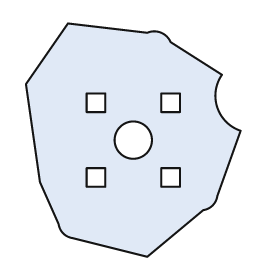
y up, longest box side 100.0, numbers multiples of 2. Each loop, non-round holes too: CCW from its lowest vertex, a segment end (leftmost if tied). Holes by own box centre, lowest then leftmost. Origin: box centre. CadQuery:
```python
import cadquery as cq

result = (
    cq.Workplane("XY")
    .moveTo(6.0, -50.0)
    .lineTo(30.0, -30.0)
    .threePointArc((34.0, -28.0), (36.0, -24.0))
    .lineTo(46.0, 4.0)
    .threePointArc((36.0, 14.0), (38.0, 28.0))
    .lineTo(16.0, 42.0)
    .threePointArc((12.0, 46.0), (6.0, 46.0))
    .lineTo(-28.0, 50.0)
    .lineTo(-46.0, 24.0)
    .lineTo(-40.0, -18.0)
    .lineTo(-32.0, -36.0)
    .threePointArc((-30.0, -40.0), (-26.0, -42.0))
    .close()
    .moveTo(-20.0, -20.0)
    .lineTo(-12.0, -20.0)
    .lineTo(-12.0, -12.0)
    .lineTo(-20.0, -12.0)
    .close()
    .moveTo(12.0, -20.0)
    .lineTo(20.0, -20.0)
    .lineTo(20.0, -12.0)
    .lineTo(12.0, -12.0)
    .close()
    .moveTo(0.0, 0.0)
    .circle(8.0)
    .moveTo(-20.0, 12.0)
    .lineTo(-12.0, 12.0)
    .lineTo(-12.0, 20.0)
    .lineTo(-20.0, 20.0)
    .close()
    .moveTo(12.0, 12.0)
    .lineTo(20.0, 12.0)
    .lineTo(20.0, 20.0)
    .lineTo(12.0, 20.0)
    .close()
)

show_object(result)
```